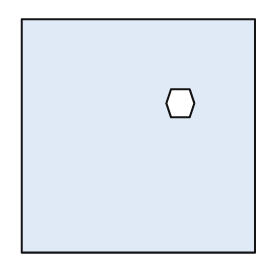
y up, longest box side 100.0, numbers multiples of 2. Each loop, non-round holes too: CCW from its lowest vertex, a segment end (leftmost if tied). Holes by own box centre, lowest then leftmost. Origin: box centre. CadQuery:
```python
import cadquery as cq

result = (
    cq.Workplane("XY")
    .moveTo(-50.0, -50.0)
    .lineTo(50.0, -50.0)
    .lineTo(50.0, 50.0)
    .lineTo(-50.0, 50.0)
    .close()
    .moveTo(14.0, 8.0)
    .lineTo(22.0, 8.0)
    .lineTo(24.0, 14.0)
    .lineTo(22.0, 20.0)
    .lineTo(14.0, 20.0)
    .lineTo(12.0, 14.0)
    .close()
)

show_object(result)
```